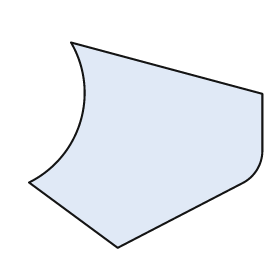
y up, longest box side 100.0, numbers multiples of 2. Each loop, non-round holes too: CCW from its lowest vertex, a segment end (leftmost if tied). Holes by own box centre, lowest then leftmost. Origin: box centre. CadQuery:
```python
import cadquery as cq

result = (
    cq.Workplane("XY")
    .moveTo(-12.0, -44.0)
    .lineTo(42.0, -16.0)
    .threePointArc((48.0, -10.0), (50.0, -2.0))
    .lineTo(50.0, 22.0)
    .lineTo(-32.0, 44.0)
    .threePointArc((-28.0, 10.0), (-50.0, -16.0))
    .close()
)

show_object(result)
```